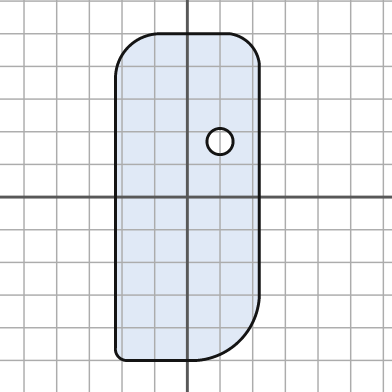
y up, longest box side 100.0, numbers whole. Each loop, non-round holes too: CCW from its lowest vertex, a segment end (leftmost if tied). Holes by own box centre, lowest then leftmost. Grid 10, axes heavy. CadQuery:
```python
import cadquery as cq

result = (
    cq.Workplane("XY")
    .moveTo(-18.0, -50.0)
    .lineTo(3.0, -50.0)
    .threePointArc((16.0, -44.0), (22.0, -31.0))
    .lineTo(22.0, 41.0)
    .threePointArc((19.0, 47.0), (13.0, 50.0))
    .lineTo(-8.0, 50.0)
    .threePointArc((-18.0, 46.0), (-22.0, 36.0))
    .lineTo(-22.0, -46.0)
    .threePointArc((-21.0, -49.0), (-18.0, -50.0))
    .close()
    .moveTo(10.0, 17.0)
    .circle(4.0)
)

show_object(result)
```